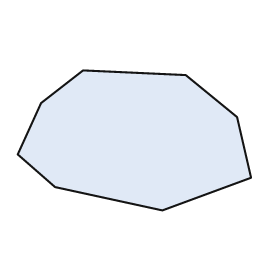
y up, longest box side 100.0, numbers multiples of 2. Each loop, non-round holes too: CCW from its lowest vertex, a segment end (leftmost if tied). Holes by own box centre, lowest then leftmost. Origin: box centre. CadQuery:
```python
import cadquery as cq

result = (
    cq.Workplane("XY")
    .moveTo(12.0, -30.0)
    .lineTo(50.0, -16.0)
    .lineTo(44.0, 10.0)
    .lineTo(22.0, 28.0)
    .lineTo(-22.0, 30.0)
    .lineTo(-40.0, 16.0)
    .lineTo(-50.0, -6.0)
    .lineTo(-34.0, -20.0)
    .close()
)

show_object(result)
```